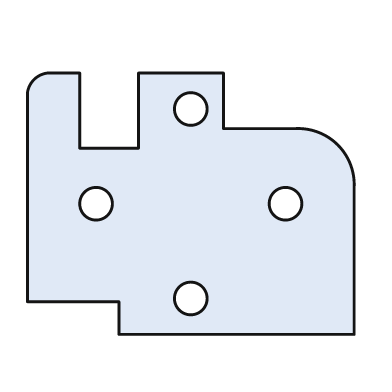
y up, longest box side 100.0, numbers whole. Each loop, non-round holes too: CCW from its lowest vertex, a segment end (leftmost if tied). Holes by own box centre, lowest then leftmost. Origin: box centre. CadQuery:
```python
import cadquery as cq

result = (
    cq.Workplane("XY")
    .moveTo(-22.0, -40.0)
    .lineTo(50.0, -40.0)
    .lineTo(50.0, 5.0)
    .threePointArc((45.0, 18.0), (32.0, 23.0))
    .lineTo(10.0, 23.0)
    .lineTo(10.0, 40.0)
    .lineTo(-16.0, 40.0)
    .lineTo(-16.0, 17.0)
    .lineTo(-34.0, 17.0)
    .lineTo(-34.0, 40.0)
    .lineTo(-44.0, 40.0)
    .threePointArc((-48.0, 38.0), (-50.0, 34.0))
    .lineTo(-50.0, -30.0)
    .lineTo(-22.0, -30.0)
    .close()
    .moveTo(0.0, -29.0)
    .circle(5.0)
    .moveTo(-29.0, 0.0)
    .circle(5.0)
    .moveTo(29.0, 0.0)
    .circle(5.0)
    .moveTo(0.0, 29.0)
    .circle(5.0)
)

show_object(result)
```